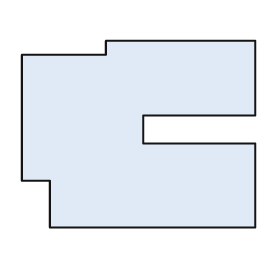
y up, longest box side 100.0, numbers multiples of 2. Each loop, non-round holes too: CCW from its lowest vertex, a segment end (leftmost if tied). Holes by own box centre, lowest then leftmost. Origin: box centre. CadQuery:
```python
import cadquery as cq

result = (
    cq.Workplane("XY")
    .moveTo(-38.0, -40.0)
    .lineTo(50.0, -40.0)
    .lineTo(50.0, -4.0)
    .lineTo(2.0, -4.0)
    .lineTo(2.0, 8.0)
    .lineTo(50.0, 8.0)
    .lineTo(50.0, 40.0)
    .lineTo(-14.0, 40.0)
    .lineTo(-14.0, 34.0)
    .lineTo(-50.0, 34.0)
    .lineTo(-50.0, -20.0)
    .lineTo(-38.0, -20.0)
    .close()
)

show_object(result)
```